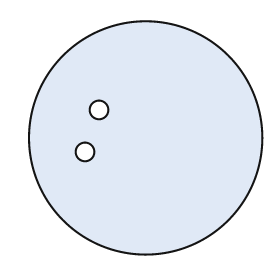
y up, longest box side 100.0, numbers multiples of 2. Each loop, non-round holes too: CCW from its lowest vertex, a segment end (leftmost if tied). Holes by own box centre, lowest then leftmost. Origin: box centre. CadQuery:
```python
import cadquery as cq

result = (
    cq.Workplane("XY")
    .moveTo(0.0, 0.0)
    .circle(50.0)
    .moveTo(-26.0, -6.0)
    .circle(4.0)
    .moveTo(-20.0, 12.0)
    .circle(4.0)
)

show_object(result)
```